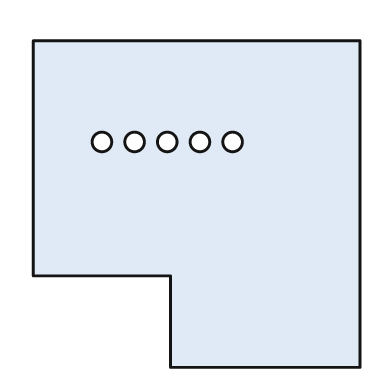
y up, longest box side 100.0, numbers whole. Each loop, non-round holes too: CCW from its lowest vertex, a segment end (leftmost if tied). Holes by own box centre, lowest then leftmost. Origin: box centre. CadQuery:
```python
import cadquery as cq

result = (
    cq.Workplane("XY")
    .moveTo(-8.0, -50.0)
    .lineTo(50.0, -50.0)
    .lineTo(50.0, 50.0)
    .lineTo(-50.0, 50.0)
    .lineTo(-50.0, -22.0)
    .lineTo(-8.0, -22.0)
    .close()
    .moveTo(-29.0, 19.0)
    .circle(3.0)
    .moveTo(-19.0, 19.0)
    .circle(3.0)
    .moveTo(-9.0, 19.0)
    .circle(3.0)
    .moveTo(1.0, 19.0)
    .circle(3.0)
    .moveTo(11.0, 19.0)
    .circle(3.0)
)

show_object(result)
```